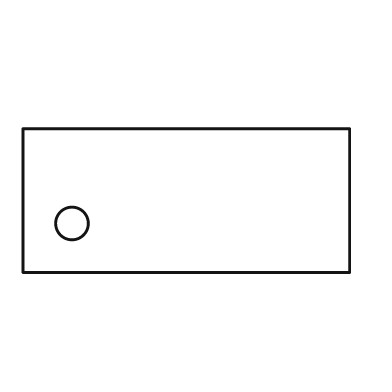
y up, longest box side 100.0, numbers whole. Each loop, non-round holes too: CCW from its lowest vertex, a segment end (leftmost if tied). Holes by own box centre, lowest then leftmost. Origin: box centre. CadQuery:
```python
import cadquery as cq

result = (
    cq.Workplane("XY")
    .moveTo(-50.0, -22.0)
    .lineTo(50.0, -22.0)
    .lineTo(50.0, 22.0)
    .lineTo(-50.0, 22.0)
    .close()
    .moveTo(-35.0, -7.0)
    .circle(5.0)
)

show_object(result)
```